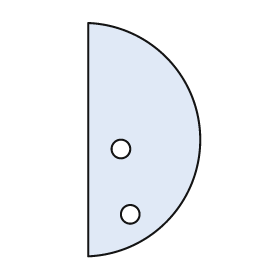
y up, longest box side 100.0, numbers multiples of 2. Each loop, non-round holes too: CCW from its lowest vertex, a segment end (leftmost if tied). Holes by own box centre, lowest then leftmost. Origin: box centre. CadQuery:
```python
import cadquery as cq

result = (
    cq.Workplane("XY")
    .moveTo(-24.0, -50.0)
    .threePointArc((24.0, 0.0), (-24.0, 50.0))
    .close()
    .moveTo(-6.0, -32.0)
    .circle(4.0)
    .moveTo(-10.0, -4.0)
    .circle(4.0)
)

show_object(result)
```